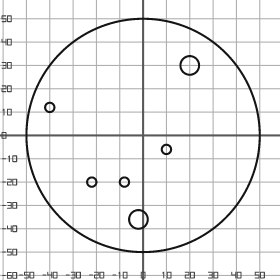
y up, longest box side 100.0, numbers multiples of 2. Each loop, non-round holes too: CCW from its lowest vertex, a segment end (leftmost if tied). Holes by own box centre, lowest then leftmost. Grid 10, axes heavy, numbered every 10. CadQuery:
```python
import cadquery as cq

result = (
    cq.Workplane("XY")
    .moveTo(0.0, 0.0)
    .circle(50.0)
    .moveTo(-2.0, -36.0)
    .circle(4.0)
    .moveTo(-22.0, -20.0)
    .circle(2.0)
    .moveTo(-8.0, -20.0)
    .circle(2.0)
    .moveTo(10.0, -6.0)
    .circle(2.0)
    .moveTo(-40.0, 12.0)
    .circle(2.0)
    .moveTo(20.0, 30.0)
    .circle(4.0)
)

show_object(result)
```